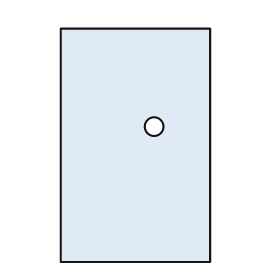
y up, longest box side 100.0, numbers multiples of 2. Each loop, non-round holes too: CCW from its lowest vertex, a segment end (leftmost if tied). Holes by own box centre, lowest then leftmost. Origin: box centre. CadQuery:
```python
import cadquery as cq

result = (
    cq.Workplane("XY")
    .moveTo(-32.0, -50.0)
    .lineTo(32.0, -50.0)
    .lineTo(32.0, 50.0)
    .lineTo(-32.0, 50.0)
    .close()
    .moveTo(8.0, 8.0)
    .circle(4.0)
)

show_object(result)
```